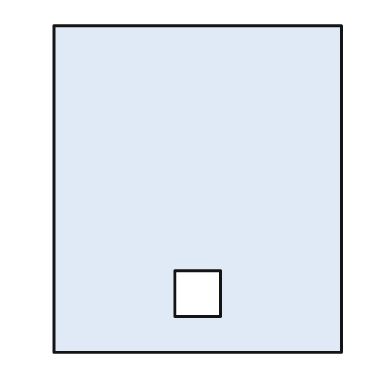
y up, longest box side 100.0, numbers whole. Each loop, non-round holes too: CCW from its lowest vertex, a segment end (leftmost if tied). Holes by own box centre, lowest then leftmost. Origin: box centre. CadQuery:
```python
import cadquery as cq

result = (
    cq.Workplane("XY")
    .moveTo(-44.0, -50.0)
    .lineTo(44.0, -50.0)
    .lineTo(44.0, 50.0)
    .lineTo(-44.0, 50.0)
    .close()
    .moveTo(-7.0, -39.0)
    .lineTo(7.0, -39.0)
    .lineTo(7.0, -25.0)
    .lineTo(-7.0, -25.0)
    .close()
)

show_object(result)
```